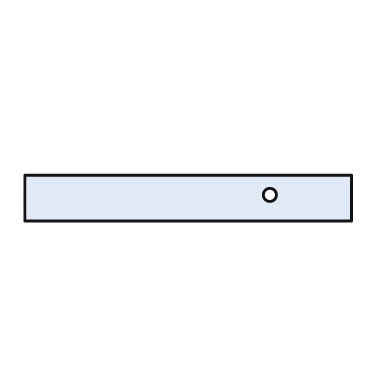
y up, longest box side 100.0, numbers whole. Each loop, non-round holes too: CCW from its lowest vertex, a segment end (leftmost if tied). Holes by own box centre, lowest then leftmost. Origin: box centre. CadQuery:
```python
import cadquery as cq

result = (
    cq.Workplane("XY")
    .moveTo(-50.0, -7.0)
    .lineTo(50.0, -7.0)
    .lineTo(50.0, 7.0)
    .lineTo(-50.0, 7.0)
    .close()
    .moveTo(25.0, 1.0)
    .circle(2.0)
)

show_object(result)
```